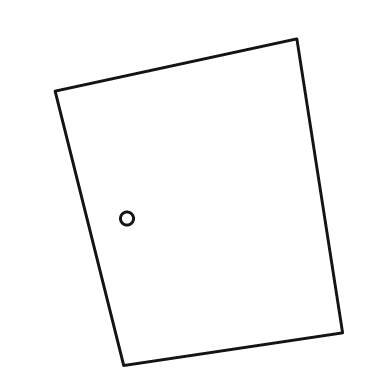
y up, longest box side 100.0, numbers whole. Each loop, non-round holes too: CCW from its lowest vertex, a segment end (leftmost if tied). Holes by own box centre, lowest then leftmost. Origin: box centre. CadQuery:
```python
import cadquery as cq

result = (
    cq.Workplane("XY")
    .moveTo(-23.0, -50.0)
    .lineTo(44.0, -40.0)
    .lineTo(30.0, 50.0)
    .lineTo(-44.0, 34.0)
    .close()
    .moveTo(-22.0, -5.0)
    .circle(2.0)
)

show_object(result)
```